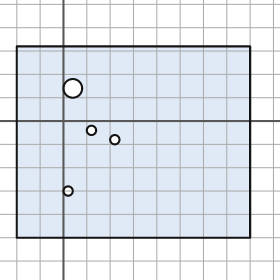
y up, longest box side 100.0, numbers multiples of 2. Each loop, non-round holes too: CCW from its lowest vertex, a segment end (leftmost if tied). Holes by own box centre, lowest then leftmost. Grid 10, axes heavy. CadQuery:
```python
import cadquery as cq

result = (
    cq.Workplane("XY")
    .moveTo(-20.0, -50.0)
    .lineTo(80.0, -50.0)
    .lineTo(80.0, 32.0)
    .lineTo(-20.0, 32.0)
    .close()
    .moveTo(2.0, -30.0)
    .circle(2.0)
    .moveTo(22.0, -8.0)
    .circle(2.0)
    .moveTo(12.0, -4.0)
    .circle(2.0)
    .moveTo(4.0, 14.0)
    .circle(4.0)
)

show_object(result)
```